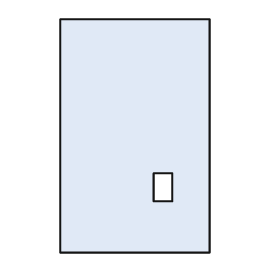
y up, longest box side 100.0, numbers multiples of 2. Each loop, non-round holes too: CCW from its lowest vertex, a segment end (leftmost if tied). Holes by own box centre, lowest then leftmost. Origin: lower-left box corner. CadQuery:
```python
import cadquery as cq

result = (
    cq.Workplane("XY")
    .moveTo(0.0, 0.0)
    .lineTo(64.0, 0.0)
    .lineTo(64.0, 100.0)
    .lineTo(0.0, 100.0)
    .close()
    .moveTo(40.0, 22.0)
    .lineTo(48.0, 22.0)
    .lineTo(48.0, 34.0)
    .lineTo(40.0, 34.0)
    .close()
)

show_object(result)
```